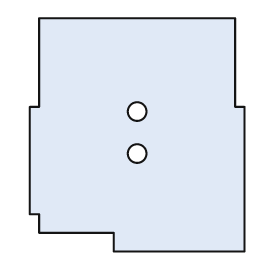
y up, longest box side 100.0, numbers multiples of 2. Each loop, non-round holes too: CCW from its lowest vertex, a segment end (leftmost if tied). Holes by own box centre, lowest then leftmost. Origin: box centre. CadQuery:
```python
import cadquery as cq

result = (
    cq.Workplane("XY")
    .moveTo(-10.0, -50.0)
    .lineTo(46.0, -50.0)
    .lineTo(46.0, 12.0)
    .lineTo(42.0, 12.0)
    .lineTo(42.0, 50.0)
    .lineTo(-42.0, 50.0)
    .lineTo(-42.0, 12.0)
    .lineTo(-46.0, 12.0)
    .lineTo(-46.0, -34.0)
    .lineTo(-42.0, -34.0)
    .lineTo(-42.0, -42.0)
    .lineTo(-10.0, -42.0)
    .close()
    .moveTo(0.0, -8.0)
    .circle(4.0)
    .moveTo(0.0, 10.0)
    .circle(4.0)
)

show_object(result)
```